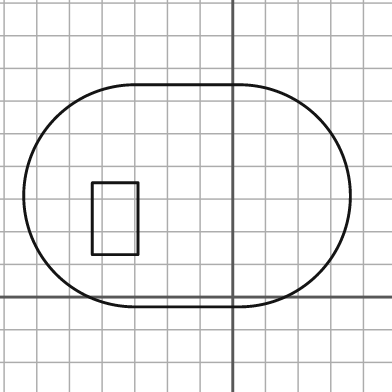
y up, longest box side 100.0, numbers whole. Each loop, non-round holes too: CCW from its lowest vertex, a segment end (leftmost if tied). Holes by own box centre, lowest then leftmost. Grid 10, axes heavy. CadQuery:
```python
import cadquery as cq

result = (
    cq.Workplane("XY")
    .moveTo(-30.0, -3.0)
    .lineTo(2.0, -3.0)
    .threePointArc((36.0, 31.0), (2.0, 65.0))
    .lineTo(-30.0, 65.0)
    .threePointArc((-64.0, 31.0), (-30.0, -3.0))
    .close()
    .moveTo(-43.0, 13.0)
    .lineTo(-29.0, 13.0)
    .lineTo(-29.0, 35.0)
    .lineTo(-43.0, 35.0)
    .close()
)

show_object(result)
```